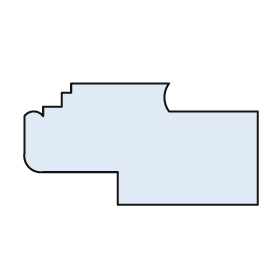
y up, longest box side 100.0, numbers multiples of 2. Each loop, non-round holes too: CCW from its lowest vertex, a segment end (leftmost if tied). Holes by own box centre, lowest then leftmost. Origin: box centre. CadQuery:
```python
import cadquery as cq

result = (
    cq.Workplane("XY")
    .moveTo(-10.0, -26.0)
    .lineTo(50.0, -26.0)
    .lineTo(50.0, 14.0)
    .lineTo(12.0, 14.0)
    .threePointArc((10.0, 20.0), (12.0, 26.0))
    .lineTo(-30.0, 26.0)
    .lineTo(-30.0, 22.0)
    .lineTo(-34.0, 22.0)
    .lineTo(-34.0, 16.0)
    .lineTo(-42.0, 16.0)
    .lineTo(-42.0, 12.0)
    .threePointArc((-46.0, 14.0), (-50.0, 12.0))
    .lineTo(-50.0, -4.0)
    .threePointArc((-48.0, -10.0), (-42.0, -12.0))
    .lineTo(-10.0, -12.0)
    .close()
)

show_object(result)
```